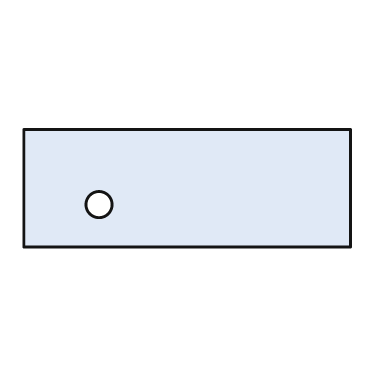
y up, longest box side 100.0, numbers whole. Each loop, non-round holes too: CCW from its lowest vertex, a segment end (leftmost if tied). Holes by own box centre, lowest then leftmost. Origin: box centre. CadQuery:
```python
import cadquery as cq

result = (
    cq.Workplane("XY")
    .moveTo(-50.0, -18.0)
    .lineTo(50.0, -18.0)
    .lineTo(50.0, 18.0)
    .lineTo(-50.0, 18.0)
    .close()
    .moveTo(-27.0, -5.0)
    .circle(4.0)
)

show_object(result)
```